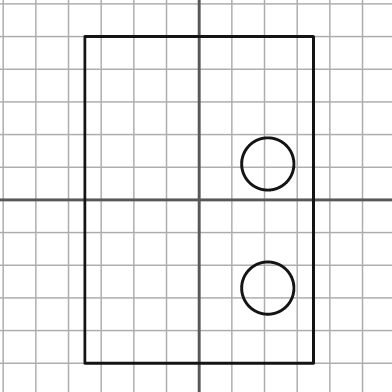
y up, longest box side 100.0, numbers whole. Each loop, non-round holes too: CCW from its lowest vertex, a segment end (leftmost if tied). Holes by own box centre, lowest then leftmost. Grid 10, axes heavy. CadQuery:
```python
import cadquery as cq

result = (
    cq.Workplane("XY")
    .moveTo(-35.0, -50.0)
    .lineTo(35.0, -50.0)
    .lineTo(35.0, 50.0)
    .lineTo(-35.0, 50.0)
    .close()
    .moveTo(21.0, -27.0)
    .circle(8.0)
    .moveTo(21.0, 11.0)
    .circle(8.0)
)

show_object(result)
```